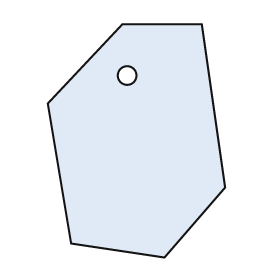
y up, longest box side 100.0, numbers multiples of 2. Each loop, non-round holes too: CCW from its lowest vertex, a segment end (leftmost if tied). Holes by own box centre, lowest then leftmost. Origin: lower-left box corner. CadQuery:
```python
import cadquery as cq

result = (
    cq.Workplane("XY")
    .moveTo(50.0, 0.0)
    .lineTo(76.0, 30.0)
    .lineTo(66.0, 100.0)
    .lineTo(32.0, 100.0)
    .lineTo(0.0, 66.0)
    .lineTo(10.0, 6.0)
    .close()
    .moveTo(34.0, 78.0)
    .circle(4.0)
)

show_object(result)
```